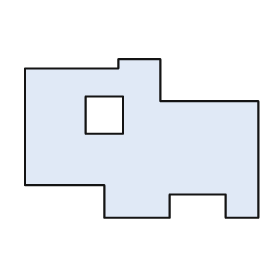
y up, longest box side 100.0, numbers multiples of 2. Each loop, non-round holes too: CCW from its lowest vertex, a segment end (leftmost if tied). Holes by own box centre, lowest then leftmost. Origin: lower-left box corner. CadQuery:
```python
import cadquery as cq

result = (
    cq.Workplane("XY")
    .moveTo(34.0, 0.0)
    .lineTo(62.0, 0.0)
    .lineTo(62.0, 10.0)
    .lineTo(86.0, 10.0)
    .lineTo(86.0, 0.0)
    .lineTo(100.0, 0.0)
    .lineTo(100.0, 50.0)
    .lineTo(58.0, 50.0)
    .lineTo(58.0, 68.0)
    .lineTo(40.0, 68.0)
    .lineTo(40.0, 64.0)
    .lineTo(0.0, 64.0)
    .lineTo(0.0, 14.0)
    .lineTo(34.0, 14.0)
    .close()
    .moveTo(26.0, 36.0)
    .lineTo(42.0, 36.0)
    .lineTo(42.0, 52.0)
    .lineTo(26.0, 52.0)
    .close()
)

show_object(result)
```